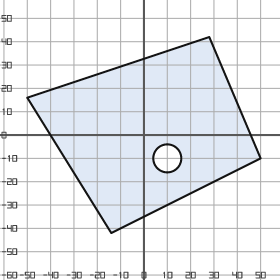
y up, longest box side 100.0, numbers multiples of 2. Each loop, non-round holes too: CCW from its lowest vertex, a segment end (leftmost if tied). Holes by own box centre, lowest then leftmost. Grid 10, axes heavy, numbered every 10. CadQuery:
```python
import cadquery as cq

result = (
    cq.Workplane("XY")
    .moveTo(-14.0, -42.0)
    .lineTo(50.0, -10.0)
    .lineTo(28.0, 42.0)
    .lineTo(-50.0, 16.0)
    .close()
    .moveTo(10.0, -10.0)
    .circle(6.0)
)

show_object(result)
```